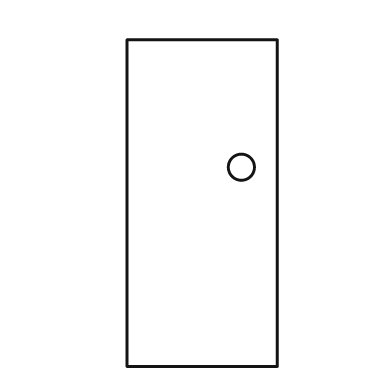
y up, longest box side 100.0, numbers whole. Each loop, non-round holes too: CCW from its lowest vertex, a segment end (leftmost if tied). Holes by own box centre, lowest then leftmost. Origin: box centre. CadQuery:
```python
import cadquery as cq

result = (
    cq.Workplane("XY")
    .moveTo(-23.0, -50.0)
    .lineTo(23.0, -50.0)
    .lineTo(23.0, 50.0)
    .lineTo(-23.0, 50.0)
    .close()
    .moveTo(12.0, 11.0)
    .circle(4.0)
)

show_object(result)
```